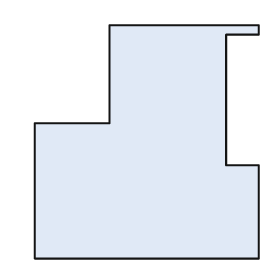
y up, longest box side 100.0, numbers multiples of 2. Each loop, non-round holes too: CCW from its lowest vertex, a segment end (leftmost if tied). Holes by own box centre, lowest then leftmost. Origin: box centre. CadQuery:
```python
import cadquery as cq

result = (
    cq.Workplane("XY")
    .moveTo(-48.0, -50.0)
    .lineTo(48.0, -50.0)
    .lineTo(48.0, -10.0)
    .lineTo(34.0, -10.0)
    .lineTo(34.0, 46.0)
    .lineTo(48.0, 46.0)
    .lineTo(48.0, 50.0)
    .lineTo(-16.0, 50.0)
    .lineTo(-16.0, 8.0)
    .lineTo(-48.0, 8.0)
    .close()
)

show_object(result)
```